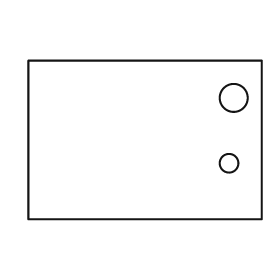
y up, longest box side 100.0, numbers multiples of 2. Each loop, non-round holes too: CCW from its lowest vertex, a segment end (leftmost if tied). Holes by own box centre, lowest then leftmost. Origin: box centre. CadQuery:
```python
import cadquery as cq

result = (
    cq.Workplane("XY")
    .moveTo(-50.0, -34.0)
    .lineTo(50.0, -34.0)
    .lineTo(50.0, 34.0)
    .lineTo(-50.0, 34.0)
    .close()
    .moveTo(36.0, -10.0)
    .circle(4.0)
    .moveTo(38.0, 18.0)
    .circle(6.0)
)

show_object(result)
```